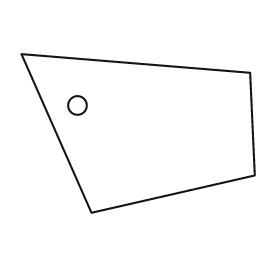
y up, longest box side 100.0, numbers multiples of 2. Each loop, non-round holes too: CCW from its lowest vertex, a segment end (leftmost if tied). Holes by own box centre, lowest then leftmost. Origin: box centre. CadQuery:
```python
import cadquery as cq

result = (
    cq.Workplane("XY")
    .moveTo(-20.0, -34.0)
    .lineTo(50.0, -18.0)
    .lineTo(48.0, 26.0)
    .lineTo(-50.0, 34.0)
    .close()
    .moveTo(-26.0, 12.0)
    .circle(4.0)
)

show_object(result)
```